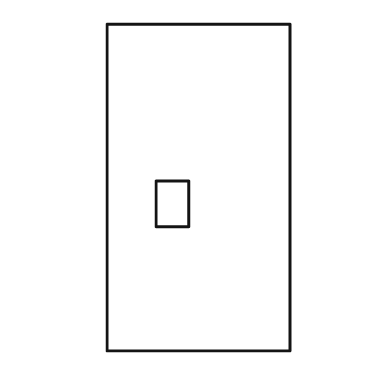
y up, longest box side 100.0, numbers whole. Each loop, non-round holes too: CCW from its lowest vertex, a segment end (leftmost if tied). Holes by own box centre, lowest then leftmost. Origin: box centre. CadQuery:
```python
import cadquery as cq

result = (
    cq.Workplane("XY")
    .moveTo(-28.0, -50.0)
    .lineTo(28.0, -50.0)
    .lineTo(28.0, 50.0)
    .lineTo(-28.0, 50.0)
    .close()
    .moveTo(-13.0, -12.0)
    .lineTo(-3.0, -12.0)
    .lineTo(-3.0, 2.0)
    .lineTo(-13.0, 2.0)
    .close()
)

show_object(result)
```